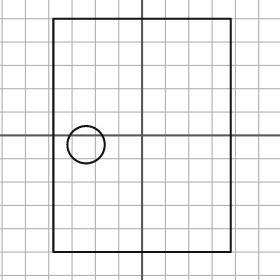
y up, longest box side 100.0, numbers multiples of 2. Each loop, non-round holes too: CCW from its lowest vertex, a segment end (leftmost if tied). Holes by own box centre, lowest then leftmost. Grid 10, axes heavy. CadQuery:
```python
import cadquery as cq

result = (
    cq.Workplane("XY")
    .moveTo(-38.0, -50.0)
    .lineTo(38.0, -50.0)
    .lineTo(38.0, 50.0)
    .lineTo(-38.0, 50.0)
    .close()
    .moveTo(-24.0, -4.0)
    .circle(8.0)
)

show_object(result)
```